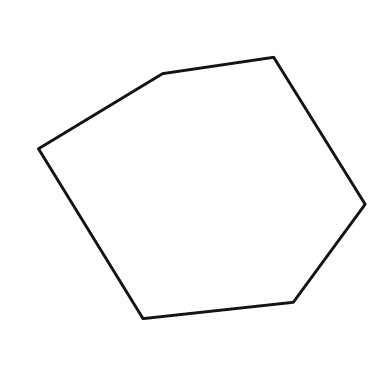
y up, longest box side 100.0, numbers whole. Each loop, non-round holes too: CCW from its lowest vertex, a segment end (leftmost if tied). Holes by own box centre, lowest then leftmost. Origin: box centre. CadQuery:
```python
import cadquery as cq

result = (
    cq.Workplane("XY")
    .moveTo(-18.0, -40.0)
    .lineTo(28.0, -35.0)
    .lineTo(50.0, -5.0)
    .lineTo(22.0, 40.0)
    .lineTo(-12.0, 35.0)
    .lineTo(-50.0, 12.0)
    .close()
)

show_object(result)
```